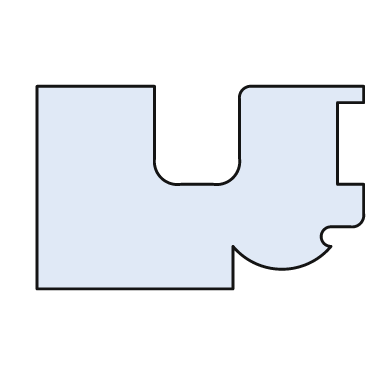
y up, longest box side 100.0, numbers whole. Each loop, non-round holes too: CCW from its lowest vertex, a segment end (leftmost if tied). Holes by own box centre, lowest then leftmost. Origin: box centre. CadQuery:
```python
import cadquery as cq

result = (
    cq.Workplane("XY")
    .moveTo(-50.0, -31.0)
    .lineTo(10.0, -31.0)
    .lineTo(10.0, -18.0)
    .threePointArc((25.0, -25.0), (40.0, -18.0))
    .threePointArc((37.0, -15.0), (40.0, -12.0))
    .lineTo(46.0, -12.0)
    .threePointArc((49.0, -11.0), (50.0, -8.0))
    .lineTo(50.0, 1.0)
    .lineTo(42.0, 1.0)
    .lineTo(42.0, 26.0)
    .lineTo(50.0, 26.0)
    .lineTo(50.0, 31.0)
    .lineTo(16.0, 31.0)
    .threePointArc((13.0, 30.0), (12.0, 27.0))
    .lineTo(12.0, 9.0)
    .threePointArc((10.0, 3.0), (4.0, 1.0))
    .lineTo(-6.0, 1.0)
    .threePointArc((-12.0, 3.0), (-14.0, 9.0))
    .lineTo(-14.0, 31.0)
    .lineTo(-50.0, 31.0)
    .close()
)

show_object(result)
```